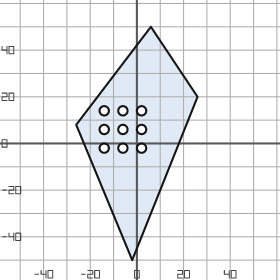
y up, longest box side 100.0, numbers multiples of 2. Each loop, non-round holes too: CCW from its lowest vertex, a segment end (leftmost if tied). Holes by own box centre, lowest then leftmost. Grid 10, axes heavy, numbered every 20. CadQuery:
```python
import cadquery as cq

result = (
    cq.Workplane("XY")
    .moveTo(-2.0, -50.0)
    .lineTo(26.0, 20.0)
    .lineTo(6.0, 50.0)
    .lineTo(-26.0, 8.0)
    .close()
    .moveTo(-14.0, -2.0)
    .circle(2.0)
    .moveTo(-6.0, -2.0)
    .circle(2.0)
    .moveTo(2.0, -2.0)
    .circle(2.0)
    .moveTo(-14.0, 6.0)
    .circle(2.0)
    .moveTo(-6.0, 6.0)
    .circle(2.0)
    .moveTo(2.0, 6.0)
    .circle(2.0)
    .moveTo(-14.0, 14.0)
    .circle(2.0)
    .moveTo(-6.0, 14.0)
    .circle(2.0)
    .moveTo(2.0, 14.0)
    .circle(2.0)
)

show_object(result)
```